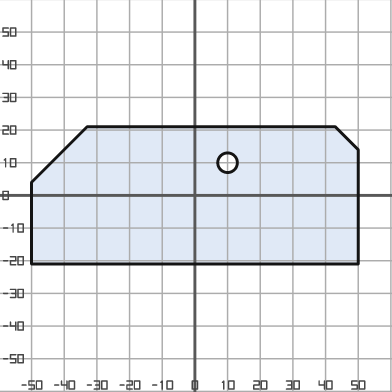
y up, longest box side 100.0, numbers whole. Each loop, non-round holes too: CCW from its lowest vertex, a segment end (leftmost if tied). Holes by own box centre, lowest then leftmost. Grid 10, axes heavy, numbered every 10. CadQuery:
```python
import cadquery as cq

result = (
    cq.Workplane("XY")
    .moveTo(-50.0, -21.0)
    .lineTo(50.0, -21.0)
    .lineTo(50.0, 14.0)
    .lineTo(43.0, 21.0)
    .lineTo(-33.0, 21.0)
    .lineTo(-50.0, 4.0)
    .close()
    .moveTo(10.0, 10.0)
    .circle(3.0)
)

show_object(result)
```